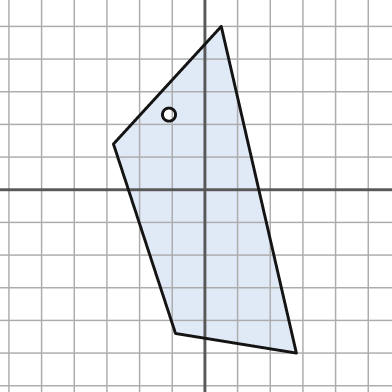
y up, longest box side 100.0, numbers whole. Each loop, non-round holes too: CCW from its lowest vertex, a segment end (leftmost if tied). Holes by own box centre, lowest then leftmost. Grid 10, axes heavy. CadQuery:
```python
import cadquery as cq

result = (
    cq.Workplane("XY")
    .moveTo(28.0, -50.0)
    .lineTo(5.0, 50.0)
    .lineTo(-28.0, 14.0)
    .lineTo(-9.0, -44.0)
    .close()
    .moveTo(-11.0, 23.0)
    .circle(2.0)
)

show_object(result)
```